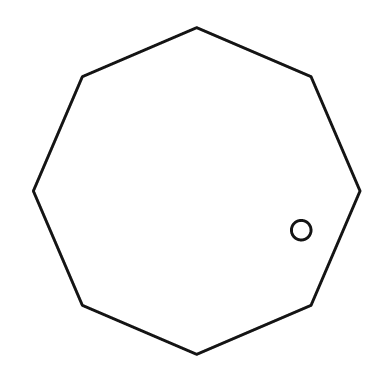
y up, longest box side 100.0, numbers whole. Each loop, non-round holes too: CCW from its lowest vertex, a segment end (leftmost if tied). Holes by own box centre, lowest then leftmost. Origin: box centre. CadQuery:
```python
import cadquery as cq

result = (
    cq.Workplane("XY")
    .moveTo(0.0, -50.0)
    .lineTo(35.0, -35.0)
    .lineTo(50.0, 0.0)
    .lineTo(35.0, 35.0)
    .lineTo(0.0, 50.0)
    .lineTo(-35.0, 35.0)
    .lineTo(-50.0, 0.0)
    .lineTo(-35.0, -35.0)
    .close()
    .moveTo(32.0, -12.0)
    .circle(3.0)
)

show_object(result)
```